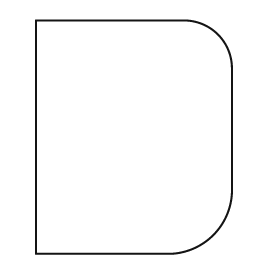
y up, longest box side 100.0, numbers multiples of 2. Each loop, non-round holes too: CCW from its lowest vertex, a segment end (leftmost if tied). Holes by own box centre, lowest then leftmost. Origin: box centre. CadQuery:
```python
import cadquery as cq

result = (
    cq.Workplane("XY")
    .moveTo(-42.0, -50.0)
    .lineTo(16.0, -50.0)
    .threePointArc((34.0, -42.0), (42.0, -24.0))
    .lineTo(42.0, 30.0)
    .threePointArc((36.0, 44.0), (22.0, 50.0))
    .lineTo(-42.0, 50.0)
    .close()
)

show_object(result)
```